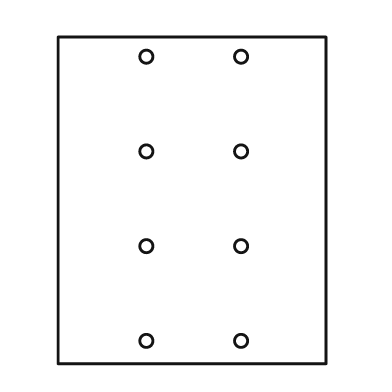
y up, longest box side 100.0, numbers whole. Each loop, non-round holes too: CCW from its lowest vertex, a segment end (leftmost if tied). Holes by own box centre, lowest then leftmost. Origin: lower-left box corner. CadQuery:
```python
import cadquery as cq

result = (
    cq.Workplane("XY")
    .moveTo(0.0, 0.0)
    .lineTo(82.0, 0.0)
    .lineTo(82.0, 100.0)
    .lineTo(0.0, 100.0)
    .close()
    .moveTo(27.0, 7.0)
    .circle(2.0)
    .moveTo(56.0, 7.0)
    .circle(2.0)
    .moveTo(27.0, 36.0)
    .circle(2.0)
    .moveTo(56.0, 36.0)
    .circle(2.0)
    .moveTo(27.0, 65.0)
    .circle(2.0)
    .moveTo(56.0, 65.0)
    .circle(2.0)
    .moveTo(27.0, 94.0)
    .circle(2.0)
    .moveTo(56.0, 94.0)
    .circle(2.0)
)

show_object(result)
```